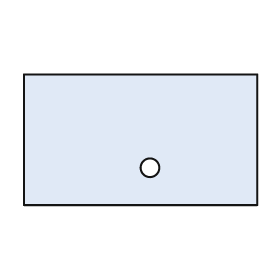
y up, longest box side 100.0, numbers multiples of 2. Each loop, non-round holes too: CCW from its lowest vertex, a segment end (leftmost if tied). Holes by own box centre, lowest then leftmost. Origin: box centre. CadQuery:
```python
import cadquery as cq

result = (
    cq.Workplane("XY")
    .moveTo(-50.0, -28.0)
    .lineTo(50.0, -28.0)
    .lineTo(50.0, 28.0)
    .lineTo(-50.0, 28.0)
    .close()
    .moveTo(4.0, -12.0)
    .circle(4.0)
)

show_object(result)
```